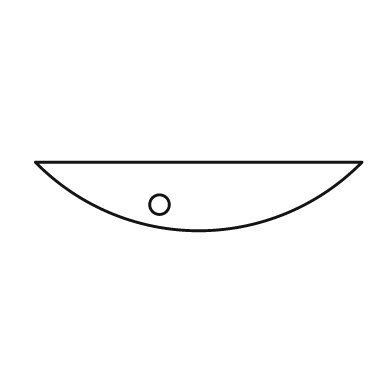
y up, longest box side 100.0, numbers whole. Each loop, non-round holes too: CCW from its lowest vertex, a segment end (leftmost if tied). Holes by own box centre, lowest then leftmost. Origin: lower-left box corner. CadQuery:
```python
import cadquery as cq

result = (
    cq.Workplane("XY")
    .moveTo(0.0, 21.0)
    .threePointArc((50.0, 0.0), (100.0, 21.0))
    .close()
    .moveTo(38.0, 8.0)
    .circle(3.0)
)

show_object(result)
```